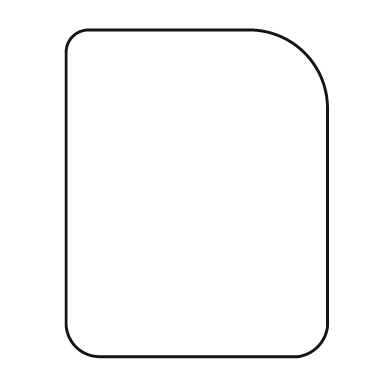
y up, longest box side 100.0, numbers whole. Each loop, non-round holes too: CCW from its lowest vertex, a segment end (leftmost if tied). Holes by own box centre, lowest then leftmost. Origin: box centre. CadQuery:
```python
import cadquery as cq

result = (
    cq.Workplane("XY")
    .moveTo(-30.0, -50.0)
    .lineTo(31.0, -50.0)
    .threePointArc((37.0, -47.0), (40.0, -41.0))
    .lineTo(40.0, 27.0)
    .threePointArc((33.0, 43.0), (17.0, 50.0))
    .lineTo(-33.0, 50.0)
    .threePointArc((-38.0, 48.0), (-40.0, 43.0))
    .lineTo(-40.0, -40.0)
    .threePointArc((-37.0, -47.0), (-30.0, -50.0))
    .close()
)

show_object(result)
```